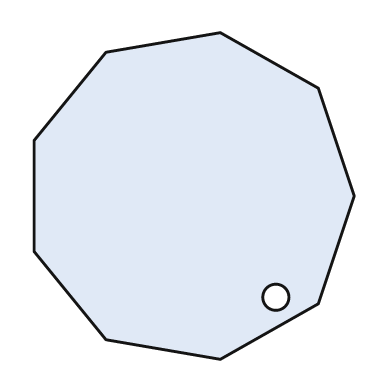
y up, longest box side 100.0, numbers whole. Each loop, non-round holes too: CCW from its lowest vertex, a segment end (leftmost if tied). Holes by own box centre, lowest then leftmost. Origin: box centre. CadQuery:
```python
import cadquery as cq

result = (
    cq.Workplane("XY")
    .moveTo(8.0, -50.0)
    .lineTo(38.0, -33.0)
    .lineTo(49.0, 0.0)
    .lineTo(38.0, 33.0)
    .lineTo(8.0, 50.0)
    .lineTo(-27.0, 44.0)
    .lineTo(-49.0, 17.0)
    .lineTo(-49.0, -17.0)
    .lineTo(-27.0, -44.0)
    .close()
    .moveTo(25.0, -31.0)
    .circle(4.0)
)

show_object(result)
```